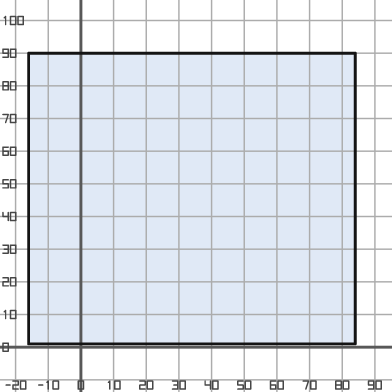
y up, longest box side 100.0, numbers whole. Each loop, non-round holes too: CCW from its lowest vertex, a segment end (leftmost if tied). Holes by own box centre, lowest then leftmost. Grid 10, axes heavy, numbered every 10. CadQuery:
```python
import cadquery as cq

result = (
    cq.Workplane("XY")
    .moveTo(-16.0, 1.0)
    .lineTo(84.0, 1.0)
    .lineTo(84.0, 90.0)
    .lineTo(-16.0, 90.0)
    .close()
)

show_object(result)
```